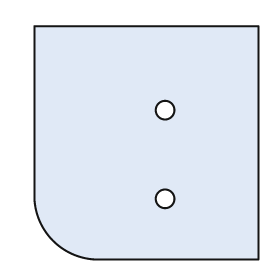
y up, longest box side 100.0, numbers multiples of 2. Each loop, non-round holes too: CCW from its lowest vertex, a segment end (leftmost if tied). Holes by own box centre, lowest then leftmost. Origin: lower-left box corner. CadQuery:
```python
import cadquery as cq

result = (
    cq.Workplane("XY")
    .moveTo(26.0, 0.0)
    .lineTo(96.0, 0.0)
    .lineTo(96.0, 100.0)
    .lineTo(0.0, 100.0)
    .lineTo(0.0, 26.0)
    .threePointArc((8.0, 8.0), (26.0, 0.0))
    .close()
    .moveTo(56.0, 26.0)
    .circle(4.0)
    .moveTo(56.0, 64.0)
    .circle(4.0)
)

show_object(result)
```